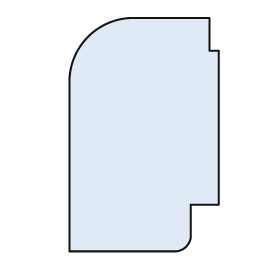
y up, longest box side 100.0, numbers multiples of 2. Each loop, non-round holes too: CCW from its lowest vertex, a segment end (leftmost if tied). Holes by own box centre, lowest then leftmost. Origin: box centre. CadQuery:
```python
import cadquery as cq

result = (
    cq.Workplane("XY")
    .moveTo(-32.0, -50.0)
    .lineTo(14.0, -50.0)
    .threePointArc((18.0, -48.0), (20.0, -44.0))
    .lineTo(20.0, -30.0)
    .lineTo(32.0, -30.0)
    .lineTo(32.0, 36.0)
    .lineTo(28.0, 36.0)
    .lineTo(28.0, 50.0)
    .lineTo(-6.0, 50.0)
    .threePointArc((-24.0, 42.0), (-32.0, 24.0))
    .close()
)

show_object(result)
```